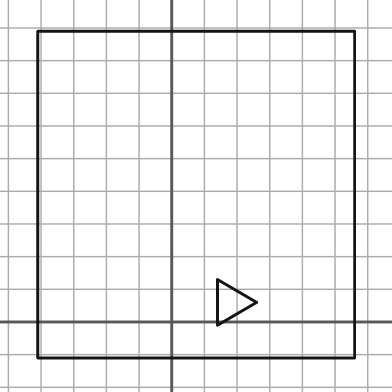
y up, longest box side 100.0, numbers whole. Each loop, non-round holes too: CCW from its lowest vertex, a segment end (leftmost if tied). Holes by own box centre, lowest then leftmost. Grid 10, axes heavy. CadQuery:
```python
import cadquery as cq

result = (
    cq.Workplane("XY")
    .moveTo(-41.0, -11.0)
    .lineTo(56.0, -11.0)
    .lineTo(56.0, 89.0)
    .lineTo(-41.0, 89.0)
    .close()
    .moveTo(14.0, -1.0)
    .lineTo(26.0, 6.0)
    .lineTo(14.0, 13.0)
    .close()
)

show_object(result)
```